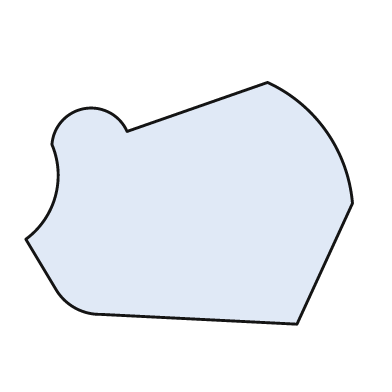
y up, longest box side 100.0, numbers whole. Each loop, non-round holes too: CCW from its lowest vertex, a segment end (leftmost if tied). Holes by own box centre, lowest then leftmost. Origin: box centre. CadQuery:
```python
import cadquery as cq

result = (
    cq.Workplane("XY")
    .moveTo(33.0, -37.0)
    .lineTo(50.0, 0.0)
    .threePointArc((42.0, 22.0), (24.0, 37.0))
    .lineTo(-19.0, 22.0)
    .threePointArc((-32.0, 29.0), (-42.0, 18.0))
    .threePointArc((-41.0, 2.0), (-50.0, -11.0))
    .lineTo(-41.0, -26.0)
    .threePointArc((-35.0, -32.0), (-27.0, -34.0))
    .close()
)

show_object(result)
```